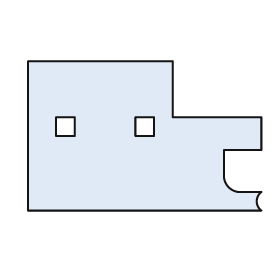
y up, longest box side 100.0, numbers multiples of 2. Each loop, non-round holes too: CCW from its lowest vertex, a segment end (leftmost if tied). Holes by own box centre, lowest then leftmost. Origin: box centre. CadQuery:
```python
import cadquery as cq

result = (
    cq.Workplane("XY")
    .moveTo(-50.0, -32.0)
    .lineTo(50.0, -32.0)
    .threePointArc((48.0, -28.0), (50.0, -24.0))
    .lineTo(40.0, -24.0)
    .threePointArc((36.0, -22.0), (34.0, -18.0))
    .lineTo(34.0, -6.0)
    .lineTo(50.0, -6.0)
    .lineTo(50.0, 8.0)
    .lineTo(12.0, 8.0)
    .lineTo(12.0, 32.0)
    .lineTo(-50.0, 32.0)
    .close()
    .moveTo(-38.0, 0.0)
    .lineTo(-30.0, 0.0)
    .lineTo(-30.0, 8.0)
    .lineTo(-38.0, 8.0)
    .close()
    .moveTo(-4.0, 0.0)
    .lineTo(4.0, 0.0)
    .lineTo(4.0, 8.0)
    .lineTo(-4.0, 8.0)
    .close()
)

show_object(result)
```